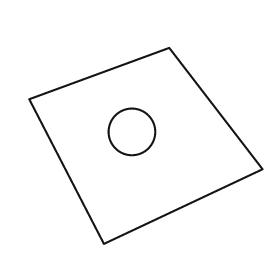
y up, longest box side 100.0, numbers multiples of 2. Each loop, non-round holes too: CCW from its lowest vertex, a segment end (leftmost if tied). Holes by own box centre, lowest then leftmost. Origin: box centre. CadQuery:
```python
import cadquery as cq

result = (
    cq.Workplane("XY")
    .moveTo(-18.0, -42.0)
    .lineTo(50.0, -10.0)
    .lineTo(10.0, 42.0)
    .lineTo(-50.0, 20.0)
    .close()
    .moveTo(-6.0, 6.0)
    .circle(10.0)
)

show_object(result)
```